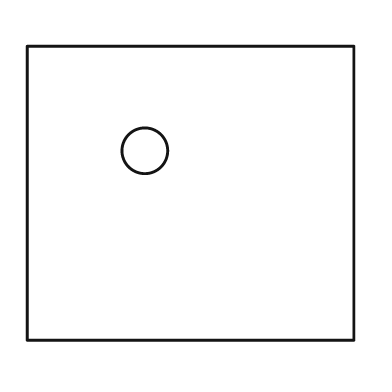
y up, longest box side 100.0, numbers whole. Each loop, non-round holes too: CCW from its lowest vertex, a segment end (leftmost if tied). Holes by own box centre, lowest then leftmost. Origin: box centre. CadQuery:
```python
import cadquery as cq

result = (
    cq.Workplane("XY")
    .moveTo(-50.0, -45.0)
    .lineTo(50.0, -45.0)
    .lineTo(50.0, 45.0)
    .lineTo(-50.0, 45.0)
    .close()
    .moveTo(-14.0, 13.0)
    .circle(7.0)
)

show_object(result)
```